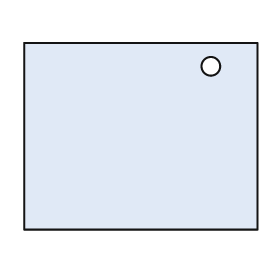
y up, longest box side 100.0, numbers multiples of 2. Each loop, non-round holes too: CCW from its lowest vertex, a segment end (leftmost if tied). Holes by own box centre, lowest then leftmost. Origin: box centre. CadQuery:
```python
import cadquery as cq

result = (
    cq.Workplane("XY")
    .moveTo(-50.0, -40.0)
    .lineTo(50.0, -40.0)
    .lineTo(50.0, 40.0)
    .lineTo(-50.0, 40.0)
    .close()
    .moveTo(30.0, 30.0)
    .circle(4.0)
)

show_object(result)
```